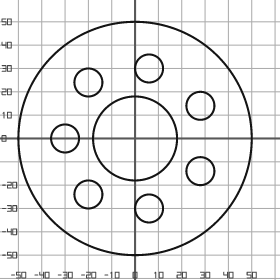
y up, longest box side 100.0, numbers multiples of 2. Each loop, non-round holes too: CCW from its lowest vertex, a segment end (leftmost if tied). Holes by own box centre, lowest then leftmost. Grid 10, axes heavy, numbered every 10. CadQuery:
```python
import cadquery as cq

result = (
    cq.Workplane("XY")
    .moveTo(0.0, 0.0)
    .circle(50.0)
    .moveTo(6.0, -30.0)
    .circle(6.0)
    .moveTo(-20.0, -24.0)
    .circle(6.0)
    .moveTo(28.0, -14.0)
    .circle(6.0)
    .moveTo(-30.0, 0.0)
    .circle(6.0)
    .moveTo(0.0, 0.0)
    .circle(18.0)
    .moveTo(28.0, 14.0)
    .circle(6.0)
    .moveTo(-20.0, 24.0)
    .circle(6.0)
    .moveTo(6.0, 30.0)
    .circle(6.0)
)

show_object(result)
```